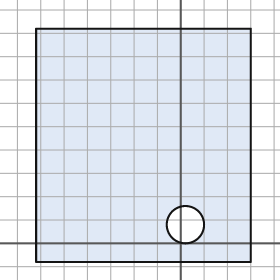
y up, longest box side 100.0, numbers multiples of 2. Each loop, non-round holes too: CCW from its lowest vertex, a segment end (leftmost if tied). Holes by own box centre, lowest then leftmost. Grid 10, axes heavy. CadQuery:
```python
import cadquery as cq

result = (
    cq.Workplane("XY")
    .moveTo(-62.0, -8.0)
    .lineTo(30.0, -8.0)
    .lineTo(30.0, 92.0)
    .lineTo(-62.0, 92.0)
    .close()
    .moveTo(2.0, 8.0)
    .circle(8.0)
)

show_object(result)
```